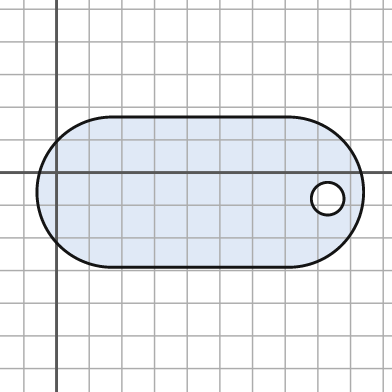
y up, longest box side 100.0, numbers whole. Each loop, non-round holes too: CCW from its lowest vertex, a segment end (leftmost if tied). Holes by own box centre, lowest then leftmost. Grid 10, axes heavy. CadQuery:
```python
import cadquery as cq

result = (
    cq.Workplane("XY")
    .moveTo(17.0, -29.0)
    .lineTo(71.0, -29.0)
    .threePointArc((94.0, -6.0), (71.0, 17.0))
    .lineTo(17.0, 17.0)
    .threePointArc((-6.0, -6.0), (17.0, -29.0))
    .close()
    .moveTo(83.0, -8.0)
    .circle(5.0)
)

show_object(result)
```